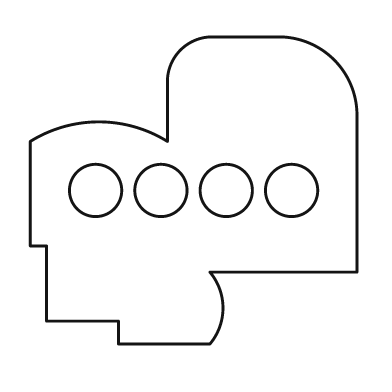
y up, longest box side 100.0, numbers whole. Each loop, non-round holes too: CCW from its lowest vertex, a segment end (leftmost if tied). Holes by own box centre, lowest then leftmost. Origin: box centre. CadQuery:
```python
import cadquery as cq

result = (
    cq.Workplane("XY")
    .moveTo(-23.0, -47.0)
    .lineTo(5.0, -47.0)
    .threePointArc((9.0, -36.0), (5.0, -25.0))
    .lineTo(50.0, -25.0)
    .lineTo(50.0, 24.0)
    .threePointArc((43.0, 40.0), (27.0, 47.0))
    .lineTo(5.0, 47.0)
    .threePointArc((-4.0, 43.0), (-8.0, 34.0))
    .lineTo(-8.0, 15.0)
    .threePointArc((-29.0, 21.0), (-50.0, 15.0))
    .lineTo(-50.0, -17.0)
    .lineTo(-45.0, -17.0)
    .lineTo(-45.0, -40.0)
    .lineTo(-23.0, -40.0)
    .close()
    .moveTo(-30.0, 0.0)
    .circle(8.0)
    .moveTo(-10.0, 0.0)
    .circle(8.0)
    .moveTo(10.0, 0.0)
    .circle(8.0)
    .moveTo(30.0, 0.0)
    .circle(8.0)
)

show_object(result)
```